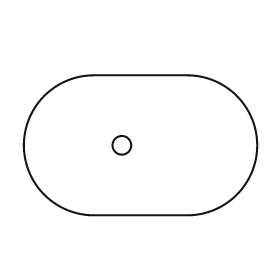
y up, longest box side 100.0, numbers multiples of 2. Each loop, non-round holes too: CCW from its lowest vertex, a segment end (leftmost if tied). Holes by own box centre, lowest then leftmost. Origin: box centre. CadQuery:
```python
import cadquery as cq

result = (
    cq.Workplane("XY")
    .moveTo(-20.0, -30.0)
    .lineTo(20.0, -30.0)
    .threePointArc((50.0, 0.0), (20.0, 30.0))
    .lineTo(-20.0, 30.0)
    .threePointArc((-50.0, 0.0), (-20.0, -30.0))
    .close()
    .moveTo(-8.0, 0.0)
    .circle(4.0)
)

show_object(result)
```